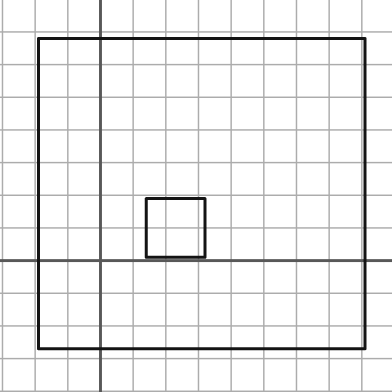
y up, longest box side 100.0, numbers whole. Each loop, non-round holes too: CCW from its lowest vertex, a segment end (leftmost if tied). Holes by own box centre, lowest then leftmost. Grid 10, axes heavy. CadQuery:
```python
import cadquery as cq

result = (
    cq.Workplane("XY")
    .moveTo(-19.0, -27.0)
    .lineTo(81.0, -27.0)
    .lineTo(81.0, 68.0)
    .lineTo(-19.0, 68.0)
    .close()
    .moveTo(14.0, 1.0)
    .lineTo(32.0, 1.0)
    .lineTo(32.0, 19.0)
    .lineTo(14.0, 19.0)
    .close()
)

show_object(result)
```